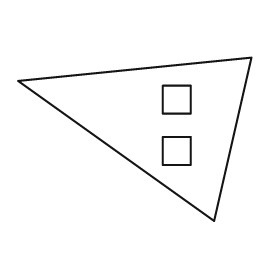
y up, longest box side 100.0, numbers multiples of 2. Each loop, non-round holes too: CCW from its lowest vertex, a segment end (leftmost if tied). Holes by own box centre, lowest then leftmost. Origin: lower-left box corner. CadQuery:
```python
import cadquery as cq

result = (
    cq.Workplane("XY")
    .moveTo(84.0, 0.0)
    .lineTo(100.0, 70.0)
    .lineTo(0.0, 60.0)
    .close()
    .moveTo(62.0, 24.0)
    .lineTo(74.0, 24.0)
    .lineTo(74.0, 36.0)
    .lineTo(62.0, 36.0)
    .close()
    .moveTo(62.0, 46.0)
    .lineTo(74.0, 46.0)
    .lineTo(74.0, 58.0)
    .lineTo(62.0, 58.0)
    .close()
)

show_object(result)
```